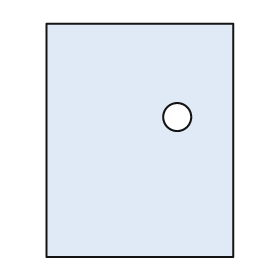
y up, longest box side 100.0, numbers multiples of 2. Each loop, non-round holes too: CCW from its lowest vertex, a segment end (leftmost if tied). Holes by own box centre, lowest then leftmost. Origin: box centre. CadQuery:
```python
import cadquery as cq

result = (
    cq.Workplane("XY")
    .moveTo(-40.0, -50.0)
    .lineTo(40.0, -50.0)
    .lineTo(40.0, 50.0)
    .lineTo(-40.0, 50.0)
    .close()
    .moveTo(16.0, 10.0)
    .circle(6.0)
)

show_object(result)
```